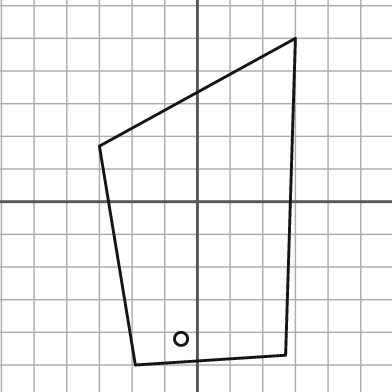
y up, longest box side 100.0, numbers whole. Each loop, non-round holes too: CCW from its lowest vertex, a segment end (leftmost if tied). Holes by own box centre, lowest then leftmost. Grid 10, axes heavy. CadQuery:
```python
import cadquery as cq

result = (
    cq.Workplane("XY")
    .moveTo(-19.0, -50.0)
    .lineTo(27.0, -47.0)
    .lineTo(30.0, 50.0)
    .lineTo(-30.0, 17.0)
    .close()
    .moveTo(-5.0, -42.0)
    .circle(2.0)
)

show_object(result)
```